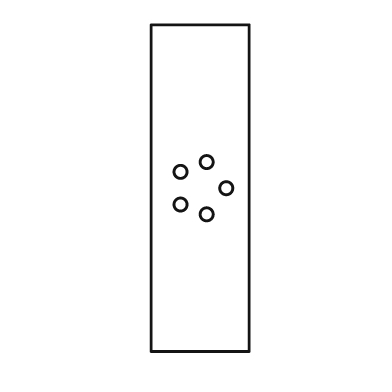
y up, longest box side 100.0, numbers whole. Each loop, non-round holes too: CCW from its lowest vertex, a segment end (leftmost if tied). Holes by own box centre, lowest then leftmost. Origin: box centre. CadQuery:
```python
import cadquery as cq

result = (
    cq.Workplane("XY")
    .moveTo(-15.0, -50.0)
    .lineTo(15.0, -50.0)
    .lineTo(15.0, 50.0)
    .lineTo(-15.0, 50.0)
    .close()
    .moveTo(2.0, -8.0)
    .circle(2.0)
    .moveTo(-6.0, -5.0)
    .circle(2.0)
    .moveTo(8.0, 0.0)
    .circle(2.0)
    .moveTo(-6.0, 5.0)
    .circle(2.0)
    .moveTo(2.0, 8.0)
    .circle(2.0)
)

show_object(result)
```